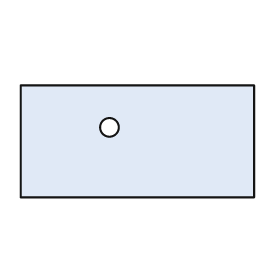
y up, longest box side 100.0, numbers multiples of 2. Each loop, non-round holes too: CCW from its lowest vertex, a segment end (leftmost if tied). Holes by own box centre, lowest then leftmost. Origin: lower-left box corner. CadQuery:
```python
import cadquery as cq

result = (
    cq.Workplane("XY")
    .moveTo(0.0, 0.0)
    .lineTo(100.0, 0.0)
    .lineTo(100.0, 48.0)
    .lineTo(0.0, 48.0)
    .close()
    .moveTo(38.0, 30.0)
    .circle(4.0)
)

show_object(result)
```